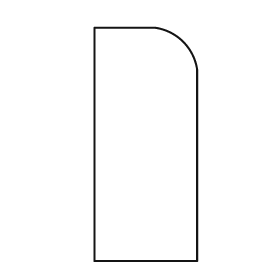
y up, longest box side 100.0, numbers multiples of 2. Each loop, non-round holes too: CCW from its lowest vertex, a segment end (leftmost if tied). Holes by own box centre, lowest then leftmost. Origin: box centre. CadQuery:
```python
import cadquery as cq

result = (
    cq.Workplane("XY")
    .moveTo(-22.0, -50.0)
    .lineTo(22.0, -50.0)
    .lineTo(22.0, 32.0)
    .threePointArc((16.0, 44.0), (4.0, 50.0))
    .lineTo(-22.0, 50.0)
    .close()
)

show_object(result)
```